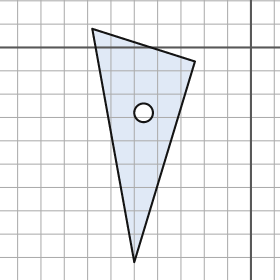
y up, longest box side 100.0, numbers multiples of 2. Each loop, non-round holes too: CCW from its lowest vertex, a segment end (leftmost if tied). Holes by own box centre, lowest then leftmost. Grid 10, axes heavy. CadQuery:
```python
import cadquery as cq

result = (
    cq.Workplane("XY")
    .moveTo(-50.0, -92.0)
    .lineTo(-24.0, -6.0)
    .lineTo(-68.0, 8.0)
    .close()
    .moveTo(-46.0, -28.0)
    .circle(4.0)
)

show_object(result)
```